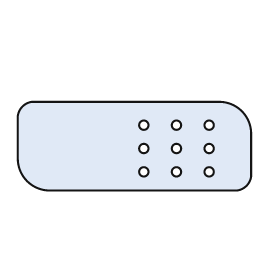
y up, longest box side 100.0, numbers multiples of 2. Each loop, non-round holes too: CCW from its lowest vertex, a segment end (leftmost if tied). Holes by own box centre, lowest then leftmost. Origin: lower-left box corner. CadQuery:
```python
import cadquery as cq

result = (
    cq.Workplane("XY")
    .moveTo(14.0, 0.0)
    .lineTo(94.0, 0.0)
    .threePointArc((98.0, 2.0), (100.0, 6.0))
    .lineTo(100.0, 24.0)
    .threePointArc((96.0, 34.0), (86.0, 38.0))
    .lineTo(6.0, 38.0)
    .threePointArc((2.0, 36.0), (0.0, 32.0))
    .lineTo(0.0, 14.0)
    .threePointArc((4.0, 4.0), (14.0, 0.0))
    .close()
    .moveTo(54.0, 8.0)
    .circle(2.0)
    .moveTo(68.0, 8.0)
    .circle(2.0)
    .moveTo(82.0, 8.0)
    .circle(2.0)
    .moveTo(54.0, 18.0)
    .circle(2.0)
    .moveTo(68.0, 18.0)
    .circle(2.0)
    .moveTo(82.0, 18.0)
    .circle(2.0)
    .moveTo(54.0, 28.0)
    .circle(2.0)
    .moveTo(68.0, 28.0)
    .circle(2.0)
    .moveTo(82.0, 28.0)
    .circle(2.0)
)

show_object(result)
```